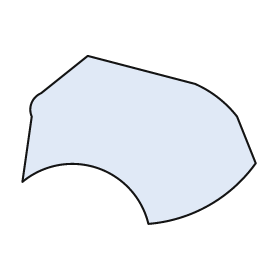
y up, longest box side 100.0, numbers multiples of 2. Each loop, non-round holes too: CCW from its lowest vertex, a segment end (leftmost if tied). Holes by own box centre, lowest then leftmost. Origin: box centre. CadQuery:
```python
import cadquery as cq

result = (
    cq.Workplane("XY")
    .moveTo(4.0, -36.0)
    .threePointArc((30.0, -28.0), (50.0, -10.0))
    .lineTo(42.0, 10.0)
    .threePointArc((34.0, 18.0), (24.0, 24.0))
    .lineTo(-22.0, 36.0)
    .lineTo(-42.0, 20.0)
    .threePointArc((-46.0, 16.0), (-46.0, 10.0))
    .lineTo(-50.0, -18.0)
    .threePointArc((-18.0, -12.0), (4.0, -36.0))
    .close()
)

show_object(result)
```